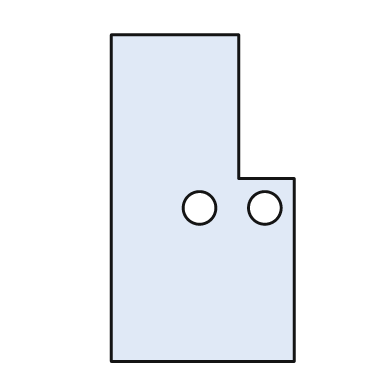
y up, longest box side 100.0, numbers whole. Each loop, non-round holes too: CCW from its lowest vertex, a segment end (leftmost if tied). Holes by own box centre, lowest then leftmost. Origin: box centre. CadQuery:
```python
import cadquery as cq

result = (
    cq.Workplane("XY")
    .moveTo(-28.0, -50.0)
    .lineTo(28.0, -50.0)
    .lineTo(28.0, 6.0)
    .lineTo(11.0, 6.0)
    .lineTo(11.0, 50.0)
    .lineTo(-28.0, 50.0)
    .close()
    .moveTo(-1.0, -3.0)
    .circle(5.0)
    .moveTo(19.0, -3.0)
    .circle(5.0)
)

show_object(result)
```